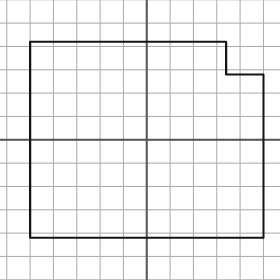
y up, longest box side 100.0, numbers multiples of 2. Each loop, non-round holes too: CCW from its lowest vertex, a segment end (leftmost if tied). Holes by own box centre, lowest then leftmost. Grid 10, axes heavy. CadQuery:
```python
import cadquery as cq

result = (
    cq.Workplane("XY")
    .moveTo(-50.0, -42.0)
    .lineTo(50.0, -42.0)
    .lineTo(50.0, 28.0)
    .lineTo(34.0, 28.0)
    .lineTo(34.0, 42.0)
    .lineTo(-50.0, 42.0)
    .close()
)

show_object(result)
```